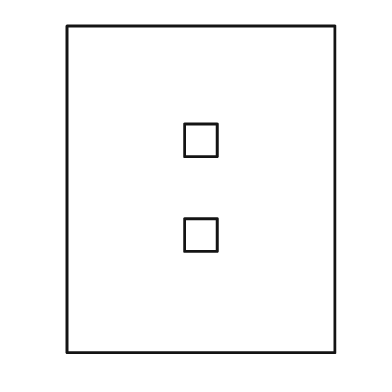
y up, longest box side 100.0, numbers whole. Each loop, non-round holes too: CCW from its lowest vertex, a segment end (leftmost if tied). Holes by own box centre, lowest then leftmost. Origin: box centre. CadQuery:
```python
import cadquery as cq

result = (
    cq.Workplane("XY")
    .moveTo(-41.0, -50.0)
    .lineTo(41.0, -50.0)
    .lineTo(41.0, 50.0)
    .lineTo(-41.0, 50.0)
    .close()
    .moveTo(-5.0, -19.0)
    .lineTo(5.0, -19.0)
    .lineTo(5.0, -9.0)
    .lineTo(-5.0, -9.0)
    .close()
    .moveTo(-5.0, 10.0)
    .lineTo(5.0, 10.0)
    .lineTo(5.0, 20.0)
    .lineTo(-5.0, 20.0)
    .close()
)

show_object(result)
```